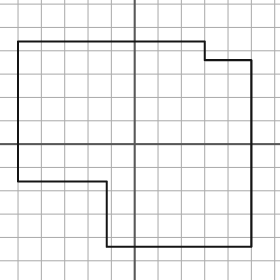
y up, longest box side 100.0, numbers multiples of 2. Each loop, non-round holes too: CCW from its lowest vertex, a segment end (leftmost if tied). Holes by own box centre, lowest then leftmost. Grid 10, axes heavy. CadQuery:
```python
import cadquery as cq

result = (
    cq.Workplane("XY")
    .moveTo(-12.0, -44.0)
    .lineTo(50.0, -44.0)
    .lineTo(50.0, 36.0)
    .lineTo(30.0, 36.0)
    .lineTo(30.0, 44.0)
    .lineTo(-50.0, 44.0)
    .lineTo(-50.0, -16.0)
    .lineTo(-12.0, -16.0)
    .close()
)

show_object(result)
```